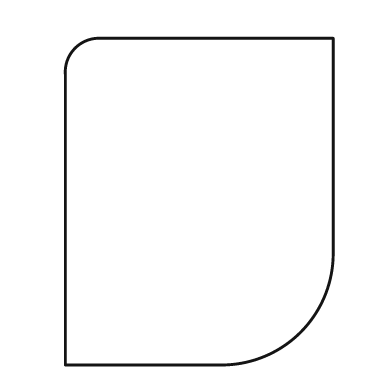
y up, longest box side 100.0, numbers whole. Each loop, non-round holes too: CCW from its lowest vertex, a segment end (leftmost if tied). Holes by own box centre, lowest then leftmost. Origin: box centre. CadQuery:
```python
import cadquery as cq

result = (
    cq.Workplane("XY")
    .moveTo(-41.0, -50.0)
    .lineTo(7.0, -50.0)
    .threePointArc((31.0, -40.0), (41.0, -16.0))
    .lineTo(41.0, 50.0)
    .lineTo(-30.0, 50.0)
    .threePointArc((-38.0, 47.0), (-41.0, 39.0))
    .close()
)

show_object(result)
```